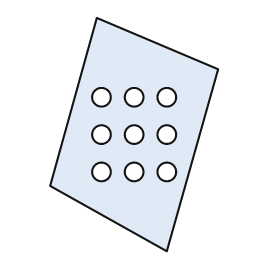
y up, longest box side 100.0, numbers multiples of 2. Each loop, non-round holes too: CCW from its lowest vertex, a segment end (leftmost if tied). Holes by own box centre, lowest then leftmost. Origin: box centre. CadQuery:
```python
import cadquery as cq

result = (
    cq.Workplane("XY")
    .moveTo(14.0, -50.0)
    .lineTo(36.0, 28.0)
    .lineTo(-16.0, 50.0)
    .lineTo(-36.0, -22.0)
    .close()
    .moveTo(-14.0, -16.0)
    .circle(4.0)
    .moveTo(0.0, -16.0)
    .circle(4.0)
    .moveTo(14.0, -16.0)
    .circle(4.0)
    .moveTo(-14.0, 0.0)
    .circle(4.0)
    .moveTo(0.0, 0.0)
    .circle(4.0)
    .moveTo(14.0, 0.0)
    .circle(4.0)
    .moveTo(-14.0, 16.0)
    .circle(4.0)
    .moveTo(0.0, 16.0)
    .circle(4.0)
    .moveTo(14.0, 16.0)
    .circle(4.0)
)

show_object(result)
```